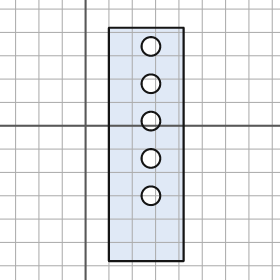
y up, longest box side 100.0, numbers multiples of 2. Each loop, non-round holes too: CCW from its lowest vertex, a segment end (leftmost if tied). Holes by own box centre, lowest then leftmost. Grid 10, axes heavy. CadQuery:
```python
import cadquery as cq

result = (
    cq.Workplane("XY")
    .moveTo(10.0, -58.0)
    .lineTo(42.0, -58.0)
    .lineTo(42.0, 42.0)
    .lineTo(10.0, 42.0)
    .close()
    .moveTo(28.0, -30.0)
    .circle(4.0)
    .moveTo(28.0, -14.0)
    .circle(4.0)
    .moveTo(28.0, 2.0)
    .circle(4.0)
    .moveTo(28.0, 18.0)
    .circle(4.0)
    .moveTo(28.0, 34.0)
    .circle(4.0)
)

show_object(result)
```